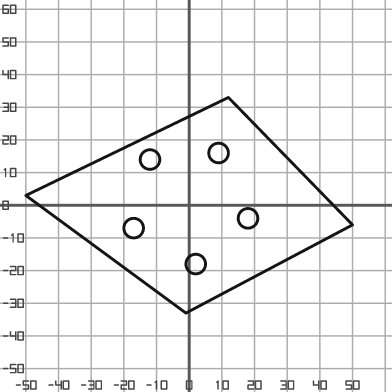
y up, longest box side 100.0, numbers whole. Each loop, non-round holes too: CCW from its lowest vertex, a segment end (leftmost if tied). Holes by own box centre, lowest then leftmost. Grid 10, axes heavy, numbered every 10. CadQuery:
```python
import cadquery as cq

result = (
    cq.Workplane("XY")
    .moveTo(-1.0, -33.0)
    .lineTo(50.0, -6.0)
    .lineTo(12.0, 33.0)
    .lineTo(-50.0, 3.0)
    .close()
    .moveTo(2.0, -18.0)
    .circle(3.0)
    .moveTo(-17.0, -7.0)
    .circle(3.0)
    .moveTo(18.0, -4.0)
    .circle(3.0)
    .moveTo(-12.0, 14.0)
    .circle(3.0)
    .moveTo(9.0, 16.0)
    .circle(3.0)
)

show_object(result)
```